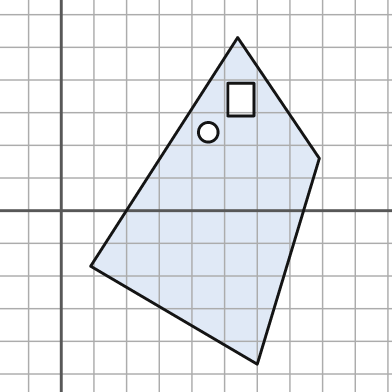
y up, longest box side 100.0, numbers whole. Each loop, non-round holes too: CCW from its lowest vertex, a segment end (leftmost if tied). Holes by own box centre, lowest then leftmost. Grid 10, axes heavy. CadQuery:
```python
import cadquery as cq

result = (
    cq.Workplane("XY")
    .moveTo(60.0, -47.0)
    .lineTo(79.0, 16.0)
    .lineTo(54.0, 53.0)
    .lineTo(9.0, -17.0)
    .close()
    .moveTo(45.0, 24.0)
    .circle(3.0)
    .moveTo(51.0, 29.0)
    .lineTo(59.0, 29.0)
    .lineTo(59.0, 39.0)
    .lineTo(51.0, 39.0)
    .close()
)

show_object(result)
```